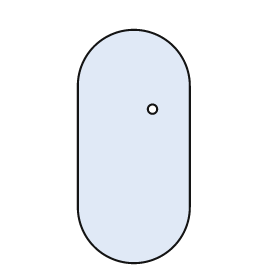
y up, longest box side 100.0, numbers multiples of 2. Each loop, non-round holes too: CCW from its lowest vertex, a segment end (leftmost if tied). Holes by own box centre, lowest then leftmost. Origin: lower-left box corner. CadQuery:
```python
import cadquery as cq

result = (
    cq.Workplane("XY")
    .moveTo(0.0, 24.0)
    .threePointArc((24.0, 0.0), (48.0, 24.0))
    .lineTo(48.0, 76.0)
    .threePointArc((24.0, 100.0), (0.0, 76.0))
    .close()
    .moveTo(32.0, 66.0)
    .circle(2.0)
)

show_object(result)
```